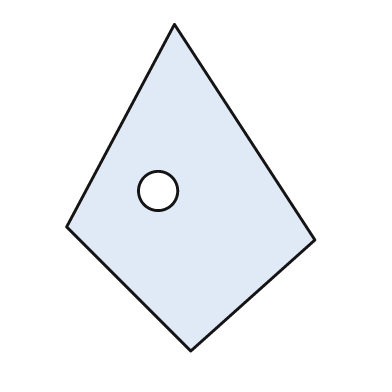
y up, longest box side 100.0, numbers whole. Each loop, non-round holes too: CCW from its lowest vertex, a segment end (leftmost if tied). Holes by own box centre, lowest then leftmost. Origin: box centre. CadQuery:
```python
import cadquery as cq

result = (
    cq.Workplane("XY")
    .moveTo(0.0, -50.0)
    .lineTo(38.0, -16.0)
    .lineTo(-5.0, 50.0)
    .lineTo(-38.0, -12.0)
    .close()
    .moveTo(-10.0, -1.0)
    .circle(6.0)
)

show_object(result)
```